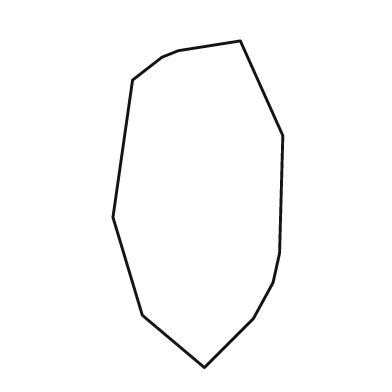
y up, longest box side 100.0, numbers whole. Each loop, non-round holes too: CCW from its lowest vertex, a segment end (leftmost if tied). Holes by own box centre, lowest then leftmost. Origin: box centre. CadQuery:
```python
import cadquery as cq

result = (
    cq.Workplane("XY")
    .moveTo(2.0, -50.0)
    .lineTo(17.0, -35.0)
    .lineTo(23.0, -24.0)
    .lineTo(25.0, -15.0)
    .lineTo(26.0, 21.0)
    .lineTo(13.0, 50.0)
    .lineTo(-6.0, 47.0)
    .lineTo(-11.0, 45.0)
    .lineTo(-20.0, 38.0)
    .lineTo(-26.0, -4.0)
    .lineTo(-17.0, -34.0)
    .close()
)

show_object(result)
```